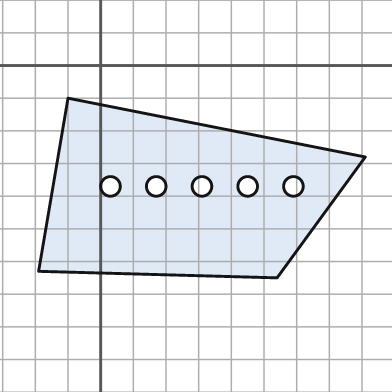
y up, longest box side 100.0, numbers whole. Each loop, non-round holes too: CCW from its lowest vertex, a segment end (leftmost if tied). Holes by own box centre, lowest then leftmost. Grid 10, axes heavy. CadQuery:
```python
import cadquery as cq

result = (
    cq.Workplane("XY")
    .moveTo(54.0, -65.0)
    .lineTo(81.0, -28.0)
    .lineTo(-10.0, -10.0)
    .lineTo(-19.0, -63.0)
    .close()
    .moveTo(3.0, -37.0)
    .circle(3.0)
    .moveTo(17.0, -37.0)
    .circle(3.0)
    .moveTo(31.0, -37.0)
    .circle(3.0)
    .moveTo(45.0, -37.0)
    .circle(3.0)
    .moveTo(59.0, -37.0)
    .circle(3.0)
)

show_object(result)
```